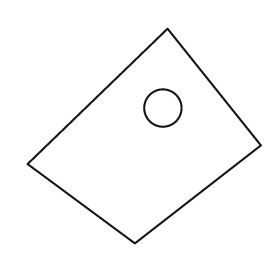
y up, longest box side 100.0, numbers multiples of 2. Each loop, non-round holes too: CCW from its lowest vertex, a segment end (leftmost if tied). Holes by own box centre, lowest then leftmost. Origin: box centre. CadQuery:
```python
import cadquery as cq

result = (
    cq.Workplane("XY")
    .moveTo(-4.0, -46.0)
    .lineTo(50.0, -4.0)
    .lineTo(10.0, 46.0)
    .lineTo(-50.0, -12.0)
    .close()
    .moveTo(8.0, 12.0)
    .circle(8.0)
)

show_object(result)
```